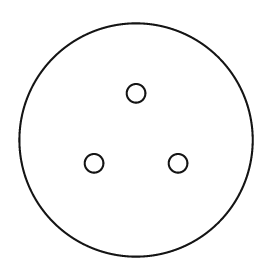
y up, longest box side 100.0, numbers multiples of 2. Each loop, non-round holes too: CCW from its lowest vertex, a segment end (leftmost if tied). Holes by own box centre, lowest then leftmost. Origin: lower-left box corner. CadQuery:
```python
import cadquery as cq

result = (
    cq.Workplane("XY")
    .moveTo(50.0, 50.0)
    .circle(50.0)
    .moveTo(32.0, 40.0)
    .circle(4.0)
    .moveTo(68.0, 40.0)
    .circle(4.0)
    .moveTo(50.0, 70.0)
    .circle(4.0)
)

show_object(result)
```